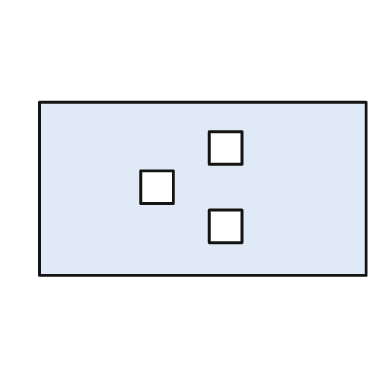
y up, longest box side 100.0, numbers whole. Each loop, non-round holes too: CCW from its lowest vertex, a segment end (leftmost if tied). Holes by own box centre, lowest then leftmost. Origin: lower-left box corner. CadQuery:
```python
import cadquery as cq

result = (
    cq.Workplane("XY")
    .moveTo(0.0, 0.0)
    .lineTo(100.0, 0.0)
    .lineTo(100.0, 53.0)
    .lineTo(0.0, 53.0)
    .close()
    .moveTo(52.0, 10.0)
    .lineTo(62.0, 10.0)
    .lineTo(62.0, 20.0)
    .lineTo(52.0, 20.0)
    .close()
    .moveTo(31.0, 22.0)
    .lineTo(41.0, 22.0)
    .lineTo(41.0, 32.0)
    .lineTo(31.0, 32.0)
    .close()
    .moveTo(52.0, 34.0)
    .lineTo(62.0, 34.0)
    .lineTo(62.0, 44.0)
    .lineTo(52.0, 44.0)
    .close()
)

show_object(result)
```